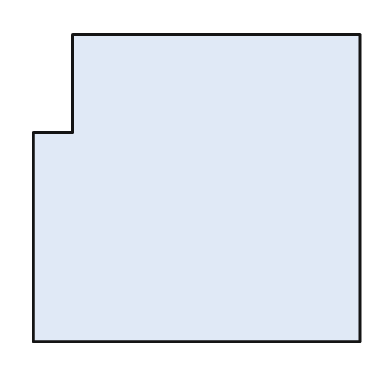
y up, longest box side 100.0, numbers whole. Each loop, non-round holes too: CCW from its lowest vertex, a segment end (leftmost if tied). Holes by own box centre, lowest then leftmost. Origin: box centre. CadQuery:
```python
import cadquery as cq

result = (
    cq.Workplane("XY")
    .moveTo(-50.0, -47.0)
    .lineTo(50.0, -47.0)
    .lineTo(50.0, 47.0)
    .lineTo(-38.0, 47.0)
    .lineTo(-38.0, 17.0)
    .lineTo(-50.0, 17.0)
    .close()
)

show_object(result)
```